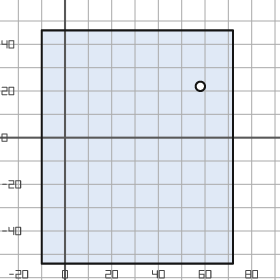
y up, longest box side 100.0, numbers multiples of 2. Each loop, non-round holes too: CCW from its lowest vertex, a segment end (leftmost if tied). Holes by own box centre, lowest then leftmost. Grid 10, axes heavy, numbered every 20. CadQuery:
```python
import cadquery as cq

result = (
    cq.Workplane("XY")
    .moveTo(-10.0, -54.0)
    .lineTo(72.0, -54.0)
    .lineTo(72.0, 46.0)
    .lineTo(-10.0, 46.0)
    .close()
    .moveTo(58.0, 22.0)
    .circle(2.0)
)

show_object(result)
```